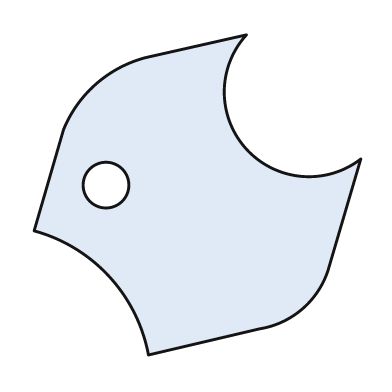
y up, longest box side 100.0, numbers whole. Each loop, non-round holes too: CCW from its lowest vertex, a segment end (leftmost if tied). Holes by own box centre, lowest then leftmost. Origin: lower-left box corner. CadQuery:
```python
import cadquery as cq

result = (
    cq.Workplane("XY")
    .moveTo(35.0, 0.0)
    .lineTo(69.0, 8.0)
    .threePointArc((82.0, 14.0), (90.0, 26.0))
    .lineTo(100.0, 60.0)
    .threePointArc((65.0, 63.0), (65.0, 98.0))
    .lineTo(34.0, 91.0)
    .threePointArc((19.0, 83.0), (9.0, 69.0))
    .lineTo(0.0, 38.0)
    .threePointArc((23.0, 24.0), (35.0, 0.0))
    .close()
    .moveTo(22.0, 52.0)
    .circle(7.0)
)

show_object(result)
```